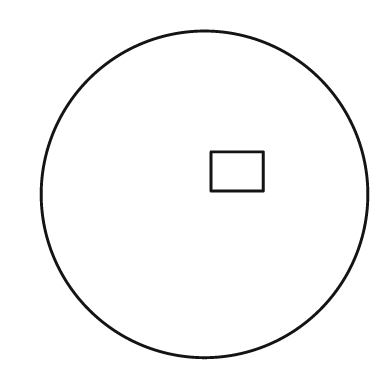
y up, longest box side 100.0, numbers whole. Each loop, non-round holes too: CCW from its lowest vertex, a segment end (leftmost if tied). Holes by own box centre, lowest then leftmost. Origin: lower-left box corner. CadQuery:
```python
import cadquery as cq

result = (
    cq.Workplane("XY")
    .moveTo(50.0, 50.0)
    .circle(50.0)
    .moveTo(52.0, 51.0)
    .lineTo(68.0, 51.0)
    .lineTo(68.0, 63.0)
    .lineTo(52.0, 63.0)
    .close()
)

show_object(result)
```